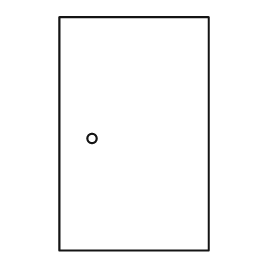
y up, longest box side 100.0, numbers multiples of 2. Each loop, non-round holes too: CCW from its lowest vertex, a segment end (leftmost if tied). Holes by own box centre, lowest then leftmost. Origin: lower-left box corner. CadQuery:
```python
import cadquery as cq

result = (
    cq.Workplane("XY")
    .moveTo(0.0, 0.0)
    .lineTo(64.0, 0.0)
    .lineTo(64.0, 100.0)
    .lineTo(0.0, 100.0)
    .close()
    .moveTo(14.0, 48.0)
    .circle(2.0)
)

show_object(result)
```